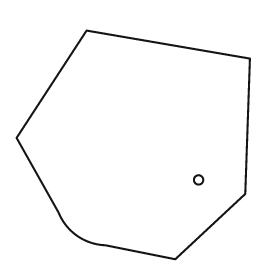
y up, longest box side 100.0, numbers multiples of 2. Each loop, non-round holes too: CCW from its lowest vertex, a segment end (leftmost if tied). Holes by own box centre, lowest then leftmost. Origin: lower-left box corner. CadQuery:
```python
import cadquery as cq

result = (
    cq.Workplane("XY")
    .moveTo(68.0, 0.0)
    .lineTo(98.0, 28.0)
    .lineTo(100.0, 86.0)
    .lineTo(30.0, 98.0)
    .lineTo(0.0, 52.0)
    .lineTo(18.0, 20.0)
    .threePointArc((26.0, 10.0), (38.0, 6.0))
    .close()
    .moveTo(78.0, 34.0)
    .circle(2.0)
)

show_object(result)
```